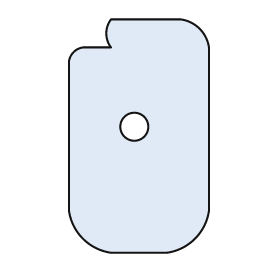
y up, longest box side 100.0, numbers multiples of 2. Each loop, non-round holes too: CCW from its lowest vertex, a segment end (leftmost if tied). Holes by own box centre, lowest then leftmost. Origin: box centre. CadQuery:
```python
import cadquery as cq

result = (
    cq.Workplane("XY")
    .moveTo(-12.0, -50.0)
    .lineTo(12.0, -50.0)
    .threePointArc((24.0, -44.0), (30.0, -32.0))
    .lineTo(30.0, 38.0)
    .threePointArc((26.0, 46.0), (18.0, 50.0))
    .lineTo(-12.0, 50.0)
    .threePointArc((-14.0, 44.0), (-12.0, 38.0))
    .lineTo(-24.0, 38.0)
    .threePointArc((-28.0, 36.0), (-30.0, 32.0))
    .lineTo(-30.0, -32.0)
    .threePointArc((-24.0, -44.0), (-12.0, -50.0))
    .close()
    .moveTo(-2.0, 4.0)
    .circle(6.0)
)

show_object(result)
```